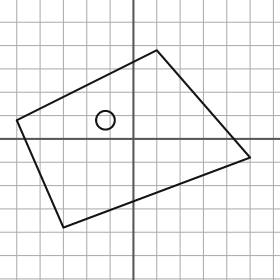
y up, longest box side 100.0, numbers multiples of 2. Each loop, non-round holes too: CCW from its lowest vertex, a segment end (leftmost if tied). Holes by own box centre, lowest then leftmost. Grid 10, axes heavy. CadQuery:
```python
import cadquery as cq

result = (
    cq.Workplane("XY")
    .moveTo(-30.0, -38.0)
    .lineTo(50.0, -8.0)
    .lineTo(10.0, 38.0)
    .lineTo(-50.0, 8.0)
    .close()
    .moveTo(-12.0, 8.0)
    .circle(4.0)
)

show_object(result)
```